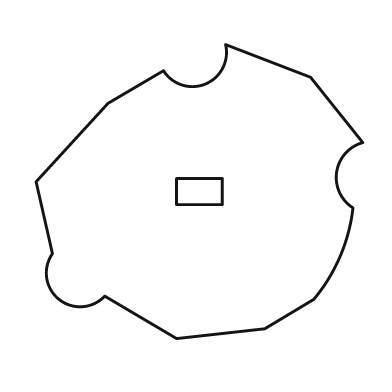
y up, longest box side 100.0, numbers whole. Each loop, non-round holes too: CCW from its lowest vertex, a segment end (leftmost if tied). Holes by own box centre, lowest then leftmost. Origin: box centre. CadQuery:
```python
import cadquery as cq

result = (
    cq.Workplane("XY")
    .moveTo(-7.0, -45.0)
    .lineTo(20.0, -42.0)
    .lineTo(35.0, -33.0)
    .threePointArc((43.0, -20.0), (47.0, -5.0))
    .threePointArc((42.0, 6.0), (50.0, 15.0))
    .lineTo(34.0, 35.0)
    .lineTo(8.0, 45.0)
    .threePointArc((2.0, 33.0), (-11.0, 37.0))
    .lineTo(-28.0, 27.0)
    .lineTo(-50.0, 3.0)
    .lineTo(-45.0, -19.0)
    .threePointArc((-43.0, -33.0), (-29.0, -32.0))
    .close()
    .moveTo(-7.0, -4.0)
    .lineTo(7.0, -4.0)
    .lineTo(7.0, 4.0)
    .lineTo(-7.0, 4.0)
    .close()
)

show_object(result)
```